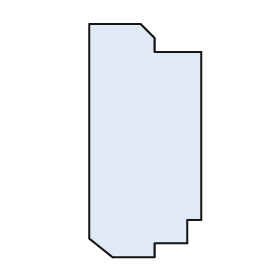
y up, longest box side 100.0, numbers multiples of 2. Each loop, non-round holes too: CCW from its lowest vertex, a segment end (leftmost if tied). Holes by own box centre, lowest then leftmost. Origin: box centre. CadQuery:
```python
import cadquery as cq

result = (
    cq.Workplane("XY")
    .moveTo(-14.0, -50.0)
    .lineTo(4.0, -50.0)
    .lineTo(4.0, -44.0)
    .lineTo(18.0, -44.0)
    .lineTo(18.0, -34.0)
    .lineTo(24.0, -34.0)
    .lineTo(24.0, 38.0)
    .lineTo(4.0, 38.0)
    .lineTo(4.0, 44.0)
    .lineTo(-2.0, 50.0)
    .lineTo(-24.0, 50.0)
    .lineTo(-24.0, -42.0)
    .close()
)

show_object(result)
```